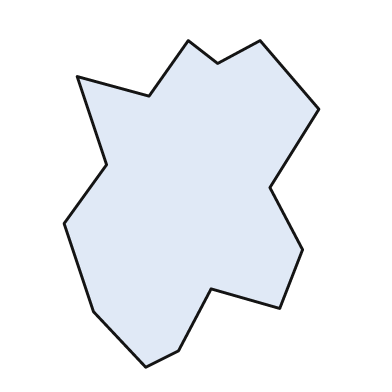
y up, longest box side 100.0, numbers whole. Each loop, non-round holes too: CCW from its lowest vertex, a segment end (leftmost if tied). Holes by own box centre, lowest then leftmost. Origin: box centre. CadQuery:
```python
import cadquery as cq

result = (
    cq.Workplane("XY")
    .moveTo(-14.0, -50.0)
    .lineTo(-4.0, -45.0)
    .lineTo(6.0, -26.0)
    .lineTo(27.0, -32.0)
    .lineTo(34.0, -14.0)
    .lineTo(24.0, 5.0)
    .lineTo(39.0, 29.0)
    .lineTo(21.0, 50.0)
    .lineTo(8.0, 43.0)
    .lineTo(-1.0, 50.0)
    .lineTo(-13.0, 33.0)
    .lineTo(-35.0, 39.0)
    .lineTo(-26.0, 12.0)
    .lineTo(-39.0, -6.0)
    .lineTo(-30.0, -33.0)
    .close()
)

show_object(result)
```